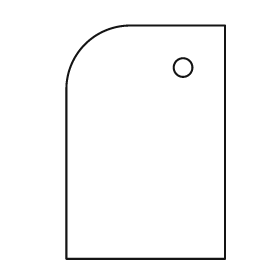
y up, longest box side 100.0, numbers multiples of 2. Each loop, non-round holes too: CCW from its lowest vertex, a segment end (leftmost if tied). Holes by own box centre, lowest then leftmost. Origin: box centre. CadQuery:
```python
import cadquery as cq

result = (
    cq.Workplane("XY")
    .moveTo(-34.0, -50.0)
    .lineTo(34.0, -50.0)
    .lineTo(34.0, 50.0)
    .lineTo(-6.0, 50.0)
    .threePointArc((-26.0, 42.0), (-34.0, 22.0))
    .close()
    .moveTo(16.0, 32.0)
    .circle(4.0)
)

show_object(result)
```